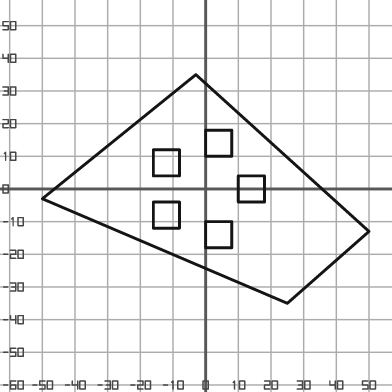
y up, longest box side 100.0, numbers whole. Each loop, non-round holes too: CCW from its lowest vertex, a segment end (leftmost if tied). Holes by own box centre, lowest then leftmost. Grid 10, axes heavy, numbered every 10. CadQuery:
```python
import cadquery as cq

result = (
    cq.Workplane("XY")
    .moveTo(25.0, -35.0)
    .lineTo(50.0, -13.0)
    .lineTo(-3.0, 35.0)
    .lineTo(-50.0, -3.0)
    .close()
    .moveTo(0.0, -18.0)
    .lineTo(8.0, -18.0)
    .lineTo(8.0, -10.0)
    .lineTo(0.0, -10.0)
    .close()
    .moveTo(-16.0, -12.0)
    .lineTo(-8.0, -12.0)
    .lineTo(-8.0, -4.0)
    .lineTo(-16.0, -4.0)
    .close()
    .moveTo(10.0, -4.0)
    .lineTo(18.0, -4.0)
    .lineTo(18.0, 4.0)
    .lineTo(10.0, 4.0)
    .close()
    .moveTo(-16.0, 4.0)
    .lineTo(-8.0, 4.0)
    .lineTo(-8.0, 12.0)
    .lineTo(-16.0, 12.0)
    .close()
    .moveTo(0.0, 10.0)
    .lineTo(8.0, 10.0)
    .lineTo(8.0, 18.0)
    .lineTo(0.0, 18.0)
    .close()
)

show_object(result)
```